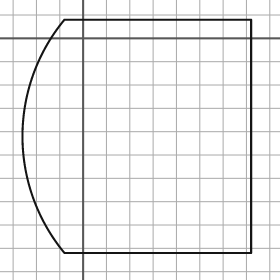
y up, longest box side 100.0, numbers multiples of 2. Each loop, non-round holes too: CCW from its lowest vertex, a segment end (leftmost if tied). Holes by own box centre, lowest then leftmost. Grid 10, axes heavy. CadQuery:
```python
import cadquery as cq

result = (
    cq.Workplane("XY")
    .moveTo(-8.0, -92.0)
    .lineTo(72.0, -92.0)
    .lineTo(72.0, 8.0)
    .lineTo(-8.0, 8.0)
    .threePointArc((-26.0, -42.0), (-8.0, -92.0))
    .close()
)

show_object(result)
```